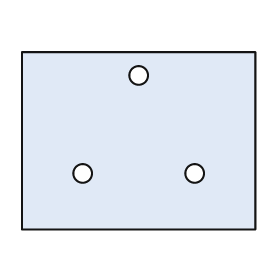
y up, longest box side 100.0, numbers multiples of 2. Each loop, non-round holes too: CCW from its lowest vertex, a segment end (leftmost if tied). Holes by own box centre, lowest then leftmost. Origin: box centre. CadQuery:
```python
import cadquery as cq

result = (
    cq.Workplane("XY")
    .moveTo(-50.0, -38.0)
    .lineTo(50.0, -38.0)
    .lineTo(50.0, 38.0)
    .lineTo(-50.0, 38.0)
    .close()
    .moveTo(-24.0, -14.0)
    .circle(4.0)
    .moveTo(24.0, -14.0)
    .circle(4.0)
    .moveTo(0.0, 28.0)
    .circle(4.0)
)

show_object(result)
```